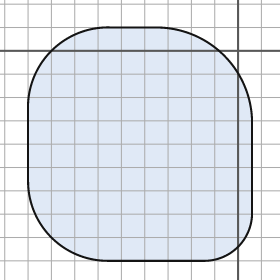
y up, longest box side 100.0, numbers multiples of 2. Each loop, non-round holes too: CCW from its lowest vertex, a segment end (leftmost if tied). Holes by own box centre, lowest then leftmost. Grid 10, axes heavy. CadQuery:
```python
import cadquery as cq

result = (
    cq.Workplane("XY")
    .moveTo(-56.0, -90.0)
    .lineTo(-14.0, -90.0)
    .threePointArc((0.0, -84.0), (6.0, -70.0))
    .lineTo(6.0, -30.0)
    .threePointArc((-6.0, -2.0), (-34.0, 10.0))
    .lineTo(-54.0, 10.0)
    .threePointArc((-80.0, 0.0), (-90.0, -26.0))
    .lineTo(-90.0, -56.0)
    .threePointArc((-80.0, -80.0), (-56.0, -90.0))
    .close()
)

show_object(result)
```